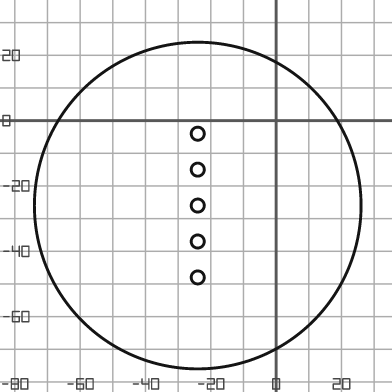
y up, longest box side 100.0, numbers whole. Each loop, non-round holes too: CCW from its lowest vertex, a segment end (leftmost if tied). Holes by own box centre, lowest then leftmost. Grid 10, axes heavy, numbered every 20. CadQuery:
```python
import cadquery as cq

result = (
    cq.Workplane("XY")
    .moveTo(-24.0, -26.0)
    .circle(50.0)
    .moveTo(-24.0, -48.0)
    .circle(2.0)
    .moveTo(-24.0, -37.0)
    .circle(2.0)
    .moveTo(-24.0, -26.0)
    .circle(2.0)
    .moveTo(-24.0, -15.0)
    .circle(2.0)
    .moveTo(-24.0, -4.0)
    .circle(2.0)
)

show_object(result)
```